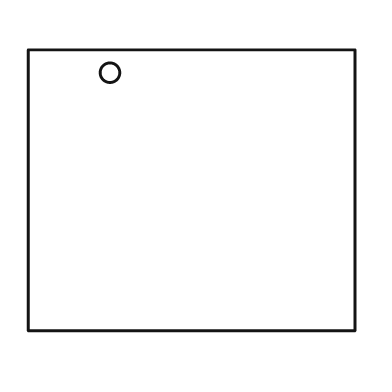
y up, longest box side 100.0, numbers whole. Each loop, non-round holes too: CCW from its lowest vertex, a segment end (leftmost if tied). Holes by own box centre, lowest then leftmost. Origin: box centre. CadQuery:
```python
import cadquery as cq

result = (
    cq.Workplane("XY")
    .moveTo(-50.0, -43.0)
    .lineTo(50.0, -43.0)
    .lineTo(50.0, 43.0)
    .lineTo(-50.0, 43.0)
    .close()
    .moveTo(-25.0, 36.0)
    .circle(3.0)
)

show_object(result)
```